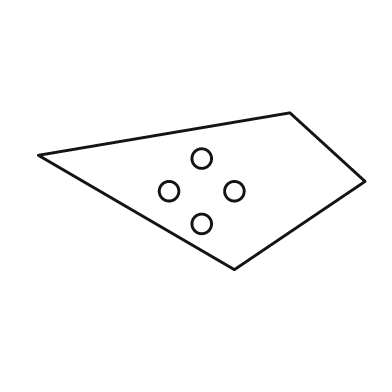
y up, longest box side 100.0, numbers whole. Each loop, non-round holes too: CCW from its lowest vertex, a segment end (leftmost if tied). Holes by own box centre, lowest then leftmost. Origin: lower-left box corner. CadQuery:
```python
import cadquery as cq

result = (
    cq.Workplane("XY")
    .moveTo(60.0, 0.0)
    .lineTo(100.0, 27.0)
    .lineTo(77.0, 48.0)
    .lineTo(0.0, 35.0)
    .close()
    .moveTo(50.0, 14.0)
    .circle(3.0)
    .moveTo(40.0, 24.0)
    .circle(3.0)
    .moveTo(60.0, 24.0)
    .circle(3.0)
    .moveTo(50.0, 34.0)
    .circle(3.0)
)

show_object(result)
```